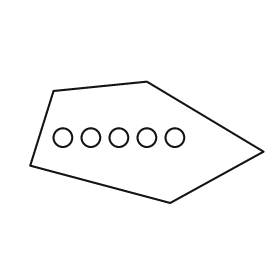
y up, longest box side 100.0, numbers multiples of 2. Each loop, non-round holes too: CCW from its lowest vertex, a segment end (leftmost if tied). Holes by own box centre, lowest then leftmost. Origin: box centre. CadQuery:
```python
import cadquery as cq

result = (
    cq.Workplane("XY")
    .moveTo(10.0, -26.0)
    .lineTo(50.0, -4.0)
    .lineTo(0.0, 26.0)
    .lineTo(-40.0, 22.0)
    .lineTo(-50.0, -10.0)
    .close()
    .moveTo(-36.0, 2.0)
    .circle(4.0)
    .moveTo(-24.0, 2.0)
    .circle(4.0)
    .moveTo(-12.0, 2.0)
    .circle(4.0)
    .moveTo(0.0, 2.0)
    .circle(4.0)
    .moveTo(12.0, 2.0)
    .circle(4.0)
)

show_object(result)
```